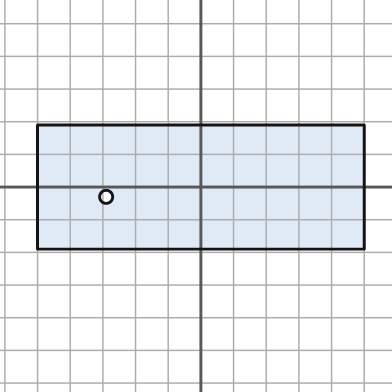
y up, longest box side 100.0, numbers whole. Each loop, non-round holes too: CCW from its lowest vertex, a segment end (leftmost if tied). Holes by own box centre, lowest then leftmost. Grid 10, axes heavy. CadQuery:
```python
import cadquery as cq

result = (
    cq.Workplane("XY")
    .moveTo(-50.0, -19.0)
    .lineTo(50.0, -19.0)
    .lineTo(50.0, 19.0)
    .lineTo(-50.0, 19.0)
    .close()
    .moveTo(-29.0, -3.0)
    .circle(2.0)
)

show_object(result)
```